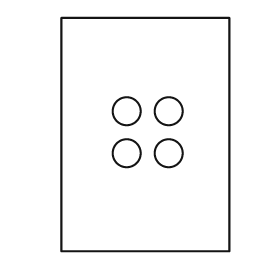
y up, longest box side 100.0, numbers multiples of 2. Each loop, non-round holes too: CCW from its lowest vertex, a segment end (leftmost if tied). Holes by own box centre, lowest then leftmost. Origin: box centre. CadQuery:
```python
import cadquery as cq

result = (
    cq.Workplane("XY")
    .moveTo(-36.0, -50.0)
    .lineTo(36.0, -50.0)
    .lineTo(36.0, 50.0)
    .lineTo(-36.0, 50.0)
    .close()
    .moveTo(-8.0, -8.0)
    .circle(6.0)
    .moveTo(10.0, -8.0)
    .circle(6.0)
    .moveTo(-8.0, 10.0)
    .circle(6.0)
    .moveTo(10.0, 10.0)
    .circle(6.0)
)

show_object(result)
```